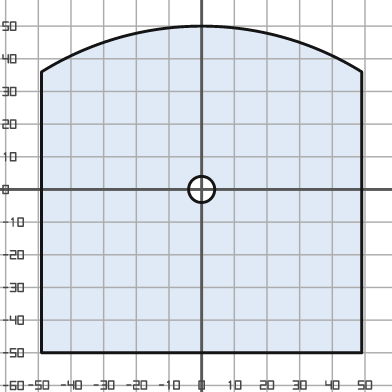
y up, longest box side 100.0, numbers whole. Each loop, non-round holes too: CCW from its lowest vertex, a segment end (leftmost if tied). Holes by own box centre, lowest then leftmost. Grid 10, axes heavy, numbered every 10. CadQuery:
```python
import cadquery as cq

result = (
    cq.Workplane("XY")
    .moveTo(-49.0, -50.0)
    .lineTo(49.0, -50.0)
    .lineTo(49.0, 36.0)
    .threePointArc((0.0, 50.0), (-49.0, 36.0))
    .close()
    .moveTo(0.0, 0.0)
    .circle(4.0)
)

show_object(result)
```